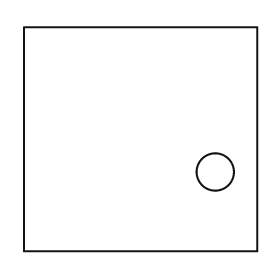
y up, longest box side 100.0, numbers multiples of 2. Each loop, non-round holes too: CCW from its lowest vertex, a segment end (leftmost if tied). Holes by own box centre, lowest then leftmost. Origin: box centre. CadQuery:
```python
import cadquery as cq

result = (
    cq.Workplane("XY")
    .moveTo(-50.0, -48.0)
    .lineTo(50.0, -48.0)
    .lineTo(50.0, 48.0)
    .lineTo(-50.0, 48.0)
    .close()
    .moveTo(32.0, -14.0)
    .circle(8.0)
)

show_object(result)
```